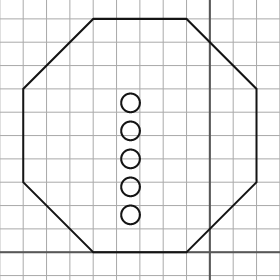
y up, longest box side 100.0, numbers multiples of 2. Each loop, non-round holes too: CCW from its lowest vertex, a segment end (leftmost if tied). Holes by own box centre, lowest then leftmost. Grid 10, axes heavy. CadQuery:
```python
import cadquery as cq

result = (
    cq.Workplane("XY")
    .moveTo(-50.0, 0.0)
    .lineTo(-10.0, 0.0)
    .lineTo(20.0, 30.0)
    .lineTo(20.0, 70.0)
    .lineTo(-10.0, 100.0)
    .lineTo(-50.0, 100.0)
    .lineTo(-80.0, 70.0)
    .lineTo(-80.0, 30.0)
    .close()
    .moveTo(-34.0, 16.0)
    .circle(4.0)
    .moveTo(-34.0, 28.0)
    .circle(4.0)
    .moveTo(-34.0, 40.0)
    .circle(4.0)
    .moveTo(-34.0, 52.0)
    .circle(4.0)
    .moveTo(-34.0, 64.0)
    .circle(4.0)
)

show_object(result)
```